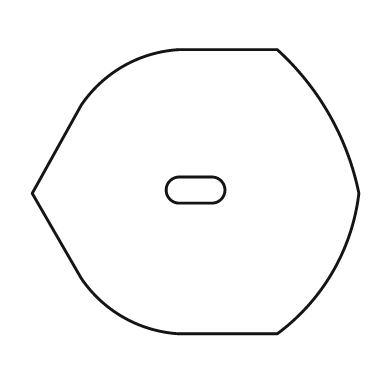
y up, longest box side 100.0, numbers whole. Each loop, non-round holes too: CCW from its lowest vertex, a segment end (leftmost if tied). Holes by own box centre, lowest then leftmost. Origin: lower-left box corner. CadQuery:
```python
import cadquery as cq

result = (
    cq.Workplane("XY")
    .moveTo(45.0, 0.0)
    .lineTo(75.0, 0.0)
    .threePointArc((92.0, 19.0), (100.0, 43.0))
    .threePointArc((91.0, 67.0), (75.0, 87.0))
    .lineTo(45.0, 87.0)
    .threePointArc((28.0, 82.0), (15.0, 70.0))
    .lineTo(0.0, 43.0)
    .lineTo(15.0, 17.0)
    .threePointArc((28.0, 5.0), (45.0, 0.0))
    .close()
    .moveTo(45.0, 40.0)
    .lineTo(55.0, 40.0)
    .threePointArc((59.0, 44.0), (55.0, 48.0))
    .lineTo(45.0, 48.0)
    .threePointArc((41.0, 44.0), (45.0, 40.0))
    .close()
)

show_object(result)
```